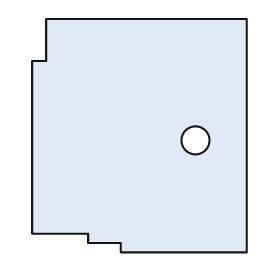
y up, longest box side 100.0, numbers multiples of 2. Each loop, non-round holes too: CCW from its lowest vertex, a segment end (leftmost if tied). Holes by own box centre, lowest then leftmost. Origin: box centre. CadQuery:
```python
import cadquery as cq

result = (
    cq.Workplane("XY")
    .moveTo(-8.0, -50.0)
    .lineTo(46.0, -50.0)
    .lineTo(46.0, 50.0)
    .lineTo(-40.0, 50.0)
    .lineTo(-40.0, 32.0)
    .lineTo(-46.0, 32.0)
    .lineTo(-46.0, -42.0)
    .lineTo(-22.0, -42.0)
    .lineTo(-22.0, -46.0)
    .lineTo(-8.0, -46.0)
    .close()
    .moveTo(24.0, -2.0)
    .circle(6.0)
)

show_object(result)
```